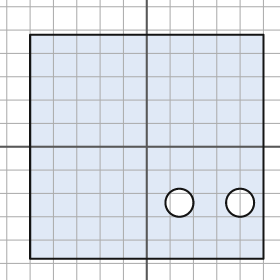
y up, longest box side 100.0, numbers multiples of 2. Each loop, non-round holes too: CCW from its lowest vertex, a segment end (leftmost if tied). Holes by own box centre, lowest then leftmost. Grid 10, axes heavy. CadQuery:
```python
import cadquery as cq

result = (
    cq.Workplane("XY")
    .moveTo(-50.0, -48.0)
    .lineTo(50.0, -48.0)
    .lineTo(50.0, 48.0)
    .lineTo(-50.0, 48.0)
    .close()
    .moveTo(14.0, -24.0)
    .circle(6.0)
    .moveTo(40.0, -24.0)
    .circle(6.0)
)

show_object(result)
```